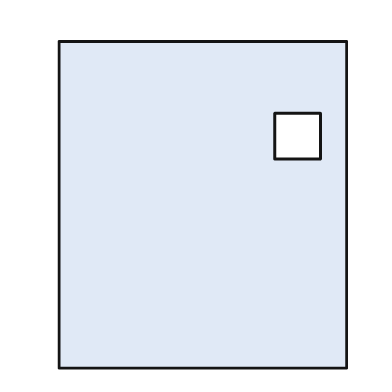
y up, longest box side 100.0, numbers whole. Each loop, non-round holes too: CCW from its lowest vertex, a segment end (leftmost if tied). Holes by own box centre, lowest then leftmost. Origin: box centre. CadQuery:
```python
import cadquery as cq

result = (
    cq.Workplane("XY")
    .moveTo(-44.0, -50.0)
    .lineTo(44.0, -50.0)
    .lineTo(44.0, 50.0)
    .lineTo(-44.0, 50.0)
    .close()
    .moveTo(22.0, 14.0)
    .lineTo(36.0, 14.0)
    .lineTo(36.0, 28.0)
    .lineTo(22.0, 28.0)
    .close()
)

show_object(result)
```